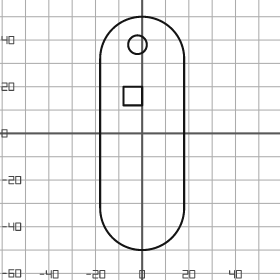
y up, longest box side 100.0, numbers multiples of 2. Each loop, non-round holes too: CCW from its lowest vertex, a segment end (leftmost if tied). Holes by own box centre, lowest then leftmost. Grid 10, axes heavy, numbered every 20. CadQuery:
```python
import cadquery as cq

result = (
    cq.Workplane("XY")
    .moveTo(-18.0, -32.0)
    .threePointArc((0.0, -50.0), (18.0, -32.0))
    .lineTo(18.0, 32.0)
    .threePointArc((0.0, 50.0), (-18.0, 32.0))
    .close()
    .moveTo(-8.0, 12.0)
    .lineTo(0.0, 12.0)
    .lineTo(0.0, 20.0)
    .lineTo(-8.0, 20.0)
    .close()
    .moveTo(-2.0, 38.0)
    .circle(4.0)
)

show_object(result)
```